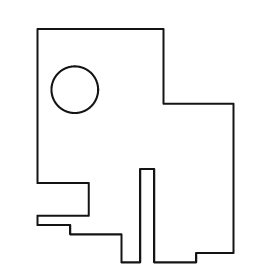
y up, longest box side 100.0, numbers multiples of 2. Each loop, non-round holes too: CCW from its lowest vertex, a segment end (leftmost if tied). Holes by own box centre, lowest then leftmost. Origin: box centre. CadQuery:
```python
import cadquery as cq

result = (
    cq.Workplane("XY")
    .moveTo(-6.0, -50.0)
    .lineTo(2.0, -50.0)
    .lineTo(2.0, -10.0)
    .lineTo(8.0, -10.0)
    .lineTo(8.0, -50.0)
    .lineTo(26.0, -50.0)
    .lineTo(26.0, -46.0)
    .lineTo(42.0, -46.0)
    .lineTo(42.0, 18.0)
    .lineTo(12.0, 18.0)
    .lineTo(12.0, 50.0)
    .lineTo(-42.0, 50.0)
    .lineTo(-42.0, -16.0)
    .lineTo(-20.0, -16.0)
    .lineTo(-20.0, -30.0)
    .lineTo(-42.0, -30.0)
    .lineTo(-42.0, -34.0)
    .lineTo(-28.0, -34.0)
    .lineTo(-28.0, -38.0)
    .lineTo(-6.0, -38.0)
    .close()
    .moveTo(-26.0, 24.0)
    .circle(10.0)
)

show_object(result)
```